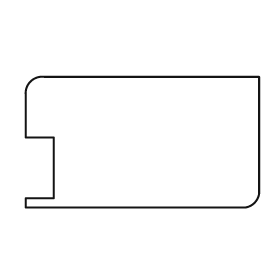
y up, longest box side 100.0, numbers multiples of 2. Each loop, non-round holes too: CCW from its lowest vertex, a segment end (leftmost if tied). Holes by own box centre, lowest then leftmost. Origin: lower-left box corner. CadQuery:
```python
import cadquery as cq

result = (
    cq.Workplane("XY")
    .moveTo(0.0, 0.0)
    .lineTo(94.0, 0.0)
    .threePointArc((98.0, 2.0), (100.0, 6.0))
    .lineTo(100.0, 56.0)
    .lineTo(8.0, 56.0)
    .threePointArc((2.0, 54.0), (0.0, 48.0))
    .lineTo(0.0, 30.0)
    .lineTo(12.0, 30.0)
    .lineTo(12.0, 4.0)
    .lineTo(0.0, 4.0)
    .close()
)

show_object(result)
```